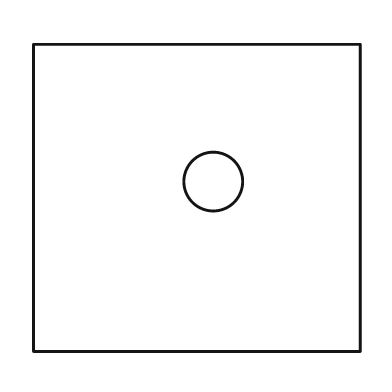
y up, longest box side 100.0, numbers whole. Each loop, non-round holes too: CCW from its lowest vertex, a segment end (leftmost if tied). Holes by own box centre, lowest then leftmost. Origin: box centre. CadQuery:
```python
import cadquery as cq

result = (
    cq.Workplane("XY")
    .moveTo(-50.0, -47.0)
    .lineTo(50.0, -47.0)
    .lineTo(50.0, 47.0)
    .lineTo(-50.0, 47.0)
    .close()
    .moveTo(5.0, 5.0)
    .circle(9.0)
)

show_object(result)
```